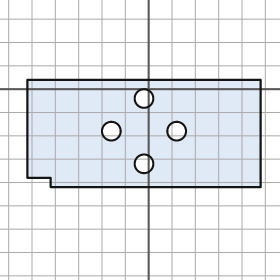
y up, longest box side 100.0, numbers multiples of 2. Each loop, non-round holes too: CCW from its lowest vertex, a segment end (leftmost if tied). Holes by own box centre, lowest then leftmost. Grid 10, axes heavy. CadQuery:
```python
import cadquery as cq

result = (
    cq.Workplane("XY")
    .moveTo(-42.0, -42.0)
    .lineTo(48.0, -42.0)
    .lineTo(48.0, 4.0)
    .lineTo(-52.0, 4.0)
    .lineTo(-52.0, -38.0)
    .lineTo(-42.0, -38.0)
    .close()
    .moveTo(-2.0, -32.0)
    .circle(4.0)
    .moveTo(-16.0, -18.0)
    .circle(4.0)
    .moveTo(12.0, -18.0)
    .circle(4.0)
    .moveTo(-2.0, -4.0)
    .circle(4.0)
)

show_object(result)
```